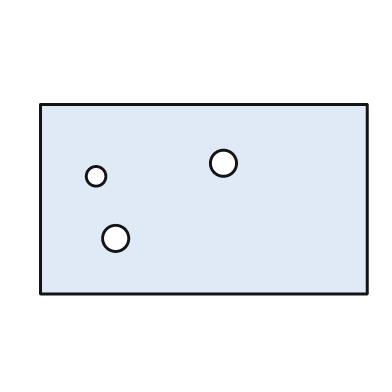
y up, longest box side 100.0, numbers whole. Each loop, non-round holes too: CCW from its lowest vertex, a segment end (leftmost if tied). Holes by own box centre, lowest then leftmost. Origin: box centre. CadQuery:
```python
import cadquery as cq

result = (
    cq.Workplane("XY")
    .moveTo(-50.0, -29.0)
    .lineTo(50.0, -29.0)
    .lineTo(50.0, 29.0)
    .lineTo(-50.0, 29.0)
    .close()
    .moveTo(-27.0, -12.0)
    .circle(4.0)
    .moveTo(-33.0, 7.0)
    .circle(3.0)
    .moveTo(6.0, 11.0)
    .circle(4.0)
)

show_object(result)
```